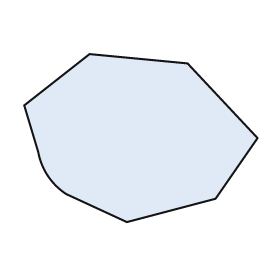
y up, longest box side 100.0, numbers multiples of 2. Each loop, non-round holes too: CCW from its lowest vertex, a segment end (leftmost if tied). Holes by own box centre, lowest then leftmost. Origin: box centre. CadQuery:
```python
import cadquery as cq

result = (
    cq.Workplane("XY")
    .moveTo(-6.0, -36.0)
    .lineTo(32.0, -26.0)
    .lineTo(50.0, 0.0)
    .lineTo(20.0, 32.0)
    .lineTo(-22.0, 36.0)
    .lineTo(-50.0, 14.0)
    .lineTo(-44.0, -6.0)
    .threePointArc((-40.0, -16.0), (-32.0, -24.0))
    .close()
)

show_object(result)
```